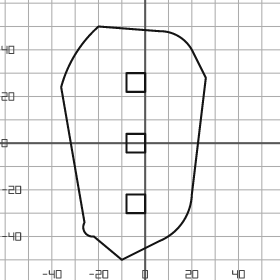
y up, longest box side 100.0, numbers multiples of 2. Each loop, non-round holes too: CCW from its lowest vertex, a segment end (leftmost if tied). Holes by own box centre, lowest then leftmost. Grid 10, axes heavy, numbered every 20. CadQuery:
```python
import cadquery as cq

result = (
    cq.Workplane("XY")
    .moveTo(-10.0, -50.0)
    .lineTo(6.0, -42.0)
    .threePointArc((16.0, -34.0), (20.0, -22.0))
    .lineTo(26.0, 28.0)
    .lineTo(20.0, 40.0)
    .threePointArc((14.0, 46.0), (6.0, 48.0))
    .lineTo(-20.0, 50.0)
    .threePointArc((-30.0, 38.0), (-36.0, 24.0))
    .lineTo(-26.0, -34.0)
    .threePointArc((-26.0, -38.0), (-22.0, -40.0))
    .close()
    .moveTo(-8.0, -30.0)
    .lineTo(0.0, -30.0)
    .lineTo(0.0, -22.0)
    .lineTo(-8.0, -22.0)
    .close()
    .moveTo(-8.0, -4.0)
    .lineTo(0.0, -4.0)
    .lineTo(0.0, 4.0)
    .lineTo(-8.0, 4.0)
    .close()
    .moveTo(-8.0, 22.0)
    .lineTo(0.0, 22.0)
    .lineTo(0.0, 30.0)
    .lineTo(-8.0, 30.0)
    .close()
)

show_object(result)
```